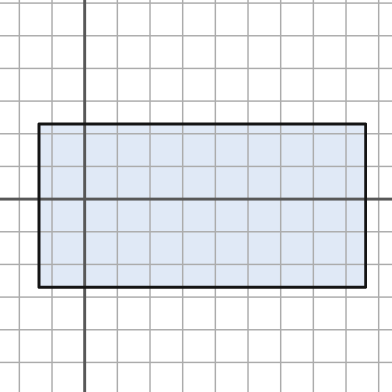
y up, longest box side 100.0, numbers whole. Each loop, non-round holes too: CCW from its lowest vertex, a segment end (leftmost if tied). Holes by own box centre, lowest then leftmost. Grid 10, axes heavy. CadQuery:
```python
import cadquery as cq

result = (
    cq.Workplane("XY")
    .moveTo(-14.0, -27.0)
    .lineTo(86.0, -27.0)
    .lineTo(86.0, 23.0)
    .lineTo(-14.0, 23.0)
    .close()
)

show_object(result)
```